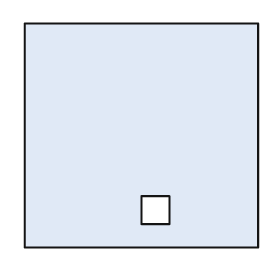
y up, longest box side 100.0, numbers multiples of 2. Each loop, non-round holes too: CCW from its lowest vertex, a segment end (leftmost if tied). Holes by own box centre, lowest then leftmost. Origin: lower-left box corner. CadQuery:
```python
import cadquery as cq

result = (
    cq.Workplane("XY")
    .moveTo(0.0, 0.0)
    .lineTo(100.0, 0.0)
    .lineTo(100.0, 96.0)
    .lineTo(0.0, 96.0)
    .close()
    .moveTo(50.0, 10.0)
    .lineTo(62.0, 10.0)
    .lineTo(62.0, 22.0)
    .lineTo(50.0, 22.0)
    .close()
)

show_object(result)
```